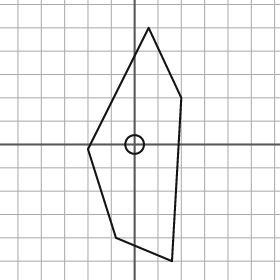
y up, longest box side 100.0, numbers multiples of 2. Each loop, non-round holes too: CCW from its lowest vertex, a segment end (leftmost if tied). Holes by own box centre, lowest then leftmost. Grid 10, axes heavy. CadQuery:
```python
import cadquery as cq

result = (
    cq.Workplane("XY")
    .moveTo(16.0, -50.0)
    .lineTo(20.0, 20.0)
    .lineTo(6.0, 50.0)
    .lineTo(-20.0, -2.0)
    .lineTo(-8.0, -40.0)
    .close()
    .moveTo(0.0, 0.0)
    .circle(4.0)
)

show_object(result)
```